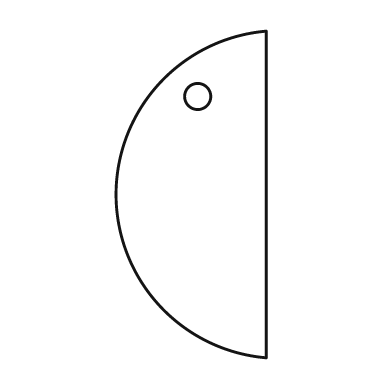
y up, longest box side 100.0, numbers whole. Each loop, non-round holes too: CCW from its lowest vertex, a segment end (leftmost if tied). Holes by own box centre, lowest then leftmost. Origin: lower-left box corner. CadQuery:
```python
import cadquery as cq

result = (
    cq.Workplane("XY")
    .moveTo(46.0, 0.0)
    .lineTo(46.0, 100.0)
    .threePointArc((0.0, 50.0), (46.0, 0.0))
    .close()
    .moveTo(25.0, 80.0)
    .circle(4.0)
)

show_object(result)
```